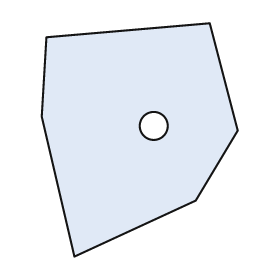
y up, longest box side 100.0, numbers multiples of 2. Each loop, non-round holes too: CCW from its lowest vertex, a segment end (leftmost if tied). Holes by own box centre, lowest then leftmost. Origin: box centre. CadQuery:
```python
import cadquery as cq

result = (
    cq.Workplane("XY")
    .moveTo(-28.0, -50.0)
    .lineTo(24.0, -26.0)
    .lineTo(42.0, 4.0)
    .lineTo(30.0, 50.0)
    .lineTo(-40.0, 44.0)
    .lineTo(-42.0, 10.0)
    .close()
    .moveTo(6.0, 6.0)
    .circle(6.0)
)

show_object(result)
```